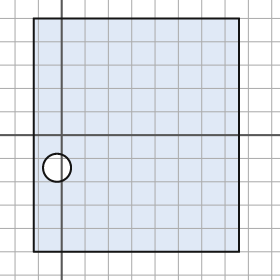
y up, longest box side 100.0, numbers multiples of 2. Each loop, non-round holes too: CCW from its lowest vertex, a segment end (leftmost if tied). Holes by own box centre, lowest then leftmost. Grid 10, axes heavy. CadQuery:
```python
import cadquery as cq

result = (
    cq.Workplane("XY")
    .moveTo(-12.0, -50.0)
    .lineTo(76.0, -50.0)
    .lineTo(76.0, 50.0)
    .lineTo(-12.0, 50.0)
    .close()
    .moveTo(-2.0, -14.0)
    .circle(6.0)
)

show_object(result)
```